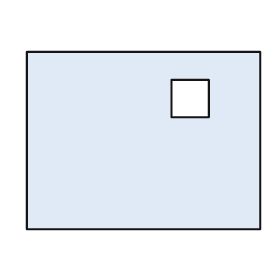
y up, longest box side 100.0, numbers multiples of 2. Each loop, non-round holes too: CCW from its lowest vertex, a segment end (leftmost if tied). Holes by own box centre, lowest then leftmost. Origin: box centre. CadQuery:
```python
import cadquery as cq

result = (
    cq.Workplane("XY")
    .moveTo(-50.0, -38.0)
    .lineTo(50.0, -38.0)
    .lineTo(50.0, 38.0)
    .lineTo(-50.0, 38.0)
    .close()
    .moveTo(12.0, 10.0)
    .lineTo(28.0, 10.0)
    .lineTo(28.0, 26.0)
    .lineTo(12.0, 26.0)
    .close()
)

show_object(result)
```